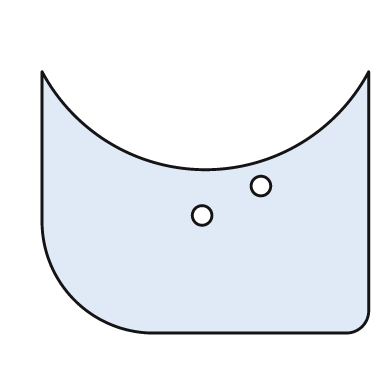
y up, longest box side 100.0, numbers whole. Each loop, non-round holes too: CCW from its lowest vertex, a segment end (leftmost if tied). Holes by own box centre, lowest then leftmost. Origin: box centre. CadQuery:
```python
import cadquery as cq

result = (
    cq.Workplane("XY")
    .moveTo(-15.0, -40.0)
    .lineTo(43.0, -40.0)
    .threePointArc((48.0, -38.0), (50.0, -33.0))
    .lineTo(50.0, 40.0)
    .threePointArc((0.0, 10.0), (-50.0, 40.0))
    .lineTo(-50.0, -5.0)
    .threePointArc((-40.0, -30.0), (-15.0, -40.0))
    .close()
    .moveTo(-1.0, -4.0)
    .circle(3.0)
    .moveTo(17.0, 5.0)
    .circle(3.0)
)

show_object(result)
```